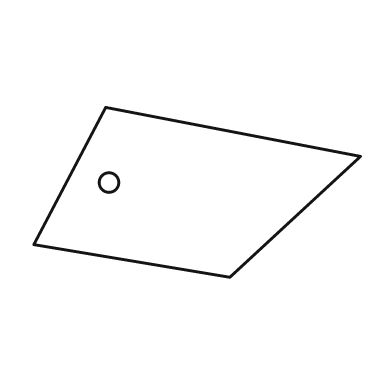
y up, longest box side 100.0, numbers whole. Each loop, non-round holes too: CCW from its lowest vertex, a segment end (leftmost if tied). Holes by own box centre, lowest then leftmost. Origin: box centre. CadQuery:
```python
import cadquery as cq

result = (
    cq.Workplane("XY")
    .moveTo(10.0, -26.0)
    .lineTo(50.0, 11.0)
    .lineTo(-28.0, 26.0)
    .lineTo(-50.0, -16.0)
    .close()
    .moveTo(-27.0, 3.0)
    .circle(3.0)
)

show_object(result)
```